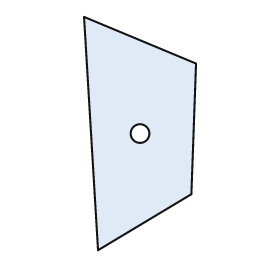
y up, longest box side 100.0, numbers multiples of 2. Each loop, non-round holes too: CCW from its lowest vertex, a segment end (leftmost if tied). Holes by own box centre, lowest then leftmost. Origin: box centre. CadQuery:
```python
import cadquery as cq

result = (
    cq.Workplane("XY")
    .moveTo(-18.0, -50.0)
    .lineTo(22.0, -26.0)
    .lineTo(24.0, 30.0)
    .lineTo(-24.0, 50.0)
    .close()
    .moveTo(0.0, 0.0)
    .circle(4.0)
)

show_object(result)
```